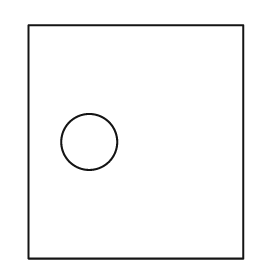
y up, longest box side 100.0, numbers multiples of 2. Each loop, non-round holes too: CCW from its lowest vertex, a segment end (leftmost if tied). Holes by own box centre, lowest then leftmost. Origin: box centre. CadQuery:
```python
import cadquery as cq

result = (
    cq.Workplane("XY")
    .moveTo(-46.0, -50.0)
    .lineTo(46.0, -50.0)
    .lineTo(46.0, 50.0)
    .lineTo(-46.0, 50.0)
    .close()
    .moveTo(-20.0, 0.0)
    .circle(12.0)
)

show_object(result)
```